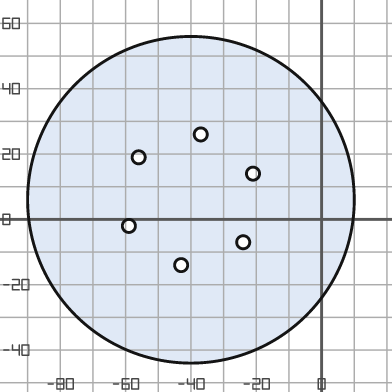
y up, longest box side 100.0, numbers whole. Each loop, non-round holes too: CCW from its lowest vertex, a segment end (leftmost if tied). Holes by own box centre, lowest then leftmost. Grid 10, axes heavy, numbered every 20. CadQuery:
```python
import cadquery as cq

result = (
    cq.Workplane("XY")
    .moveTo(-40.0, 6.0)
    .circle(50.0)
    .moveTo(-43.0, -14.0)
    .circle(2.0)
    .moveTo(-24.0, -7.0)
    .circle(2.0)
    .moveTo(-59.0, -2.0)
    .circle(2.0)
    .moveTo(-21.0, 14.0)
    .circle(2.0)
    .moveTo(-56.0, 19.0)
    .circle(2.0)
    .moveTo(-37.0, 26.0)
    .circle(2.0)
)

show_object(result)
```